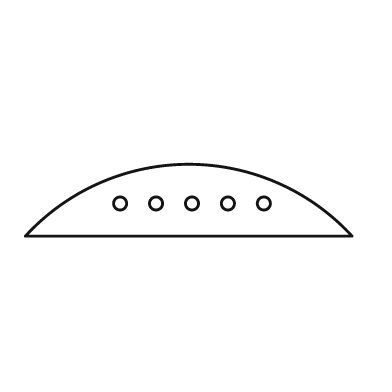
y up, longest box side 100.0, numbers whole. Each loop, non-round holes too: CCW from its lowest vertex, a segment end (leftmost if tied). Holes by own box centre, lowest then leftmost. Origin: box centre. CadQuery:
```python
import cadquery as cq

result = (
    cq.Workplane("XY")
    .moveTo(-50.0, -11.0)
    .lineTo(50.0, -11.0)
    .threePointArc((0.0, 11.0), (-50.0, -11.0))
    .close()
    .moveTo(-21.0, -1.0)
    .circle(2.0)
    .moveTo(-10.0, -1.0)
    .circle(2.0)
    .moveTo(1.0, -1.0)
    .circle(2.0)
    .moveTo(12.0, -1.0)
    .circle(2.0)
    .moveTo(23.0, -1.0)
    .circle(2.0)
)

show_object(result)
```